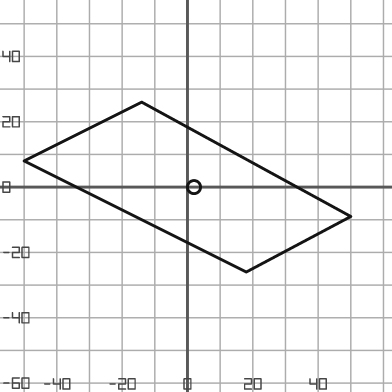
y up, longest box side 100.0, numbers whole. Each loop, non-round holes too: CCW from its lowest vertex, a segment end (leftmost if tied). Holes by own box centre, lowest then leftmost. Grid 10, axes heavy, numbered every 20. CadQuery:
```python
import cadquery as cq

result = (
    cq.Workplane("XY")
    .moveTo(18.0, -26.0)
    .lineTo(50.0, -9.0)
    .lineTo(-14.0, 26.0)
    .lineTo(-50.0, 8.0)
    .close()
    .moveTo(2.0, 0.0)
    .circle(2.0)
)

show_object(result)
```